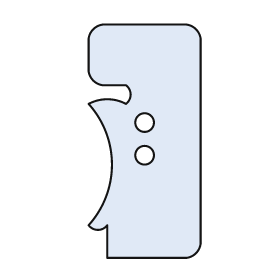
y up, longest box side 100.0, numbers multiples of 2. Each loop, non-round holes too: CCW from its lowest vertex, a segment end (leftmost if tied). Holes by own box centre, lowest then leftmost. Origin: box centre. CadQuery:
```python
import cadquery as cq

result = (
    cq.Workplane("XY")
    .moveTo(-16.0, -50.0)
    .lineTo(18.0, -50.0)
    .threePointArc((22.0, -48.0), (24.0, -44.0))
    .lineTo(24.0, 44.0)
    .threePointArc((22.0, 48.0), (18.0, 50.0))
    .lineTo(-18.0, 50.0)
    .threePointArc((-22.0, 48.0), (-24.0, 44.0))
    .lineTo(-24.0, 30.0)
    .threePointArc((-22.0, 26.0), (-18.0, 24.0))
    .lineTo(-8.0, 24.0)
    .threePointArc((-6.0, 20.0), (-8.0, 16.0))
    .threePointArc((-16.0, 18.0), (-24.0, 16.0))
    .threePointArc((-14.0, -10.0), (-24.0, -36.0))
    .threePointArc((-20.0, -38.0), (-16.0, -36.0))
    .close()
    .moveTo(0.0, -6.0)
    .circle(4.0)
    .moveTo(0.0, 8.0)
    .circle(4.0)
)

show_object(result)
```